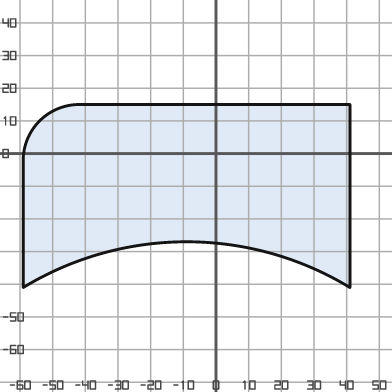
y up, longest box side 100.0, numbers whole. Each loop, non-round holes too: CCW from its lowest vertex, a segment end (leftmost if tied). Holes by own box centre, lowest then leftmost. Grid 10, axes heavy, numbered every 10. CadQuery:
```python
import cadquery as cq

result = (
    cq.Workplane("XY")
    .moveTo(-59.0, -41.0)
    .threePointArc((-9.0, -27.0), (41.0, -41.0))
    .lineTo(41.0, 15.0)
    .lineTo(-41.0, 15.0)
    .threePointArc((-54.0, 10.0), (-59.0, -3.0))
    .close()
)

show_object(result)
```